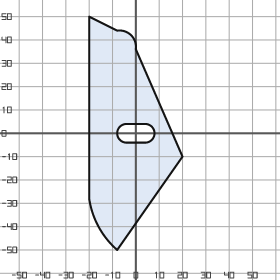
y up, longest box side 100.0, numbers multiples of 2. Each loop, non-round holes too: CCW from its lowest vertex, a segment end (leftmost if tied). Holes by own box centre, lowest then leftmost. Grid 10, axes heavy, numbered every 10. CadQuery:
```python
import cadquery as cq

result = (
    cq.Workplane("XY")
    .moveTo(-8.0, -50.0)
    .lineTo(20.0, -10.0)
    .lineTo(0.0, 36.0)
    .threePointArc((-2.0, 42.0), (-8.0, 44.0))
    .lineTo(-20.0, 50.0)
    .lineTo(-20.0, -28.0)
    .threePointArc((-16.0, -40.0), (-8.0, -50.0))
    .close()
    .moveTo(-4.0, -4.0)
    .lineTo(4.0, -4.0)
    .threePointArc((8.0, 0.0), (4.0, 4.0))
    .lineTo(-4.0, 4.0)
    .threePointArc((-8.0, 0.0), (-4.0, -4.0))
    .close()
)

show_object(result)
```